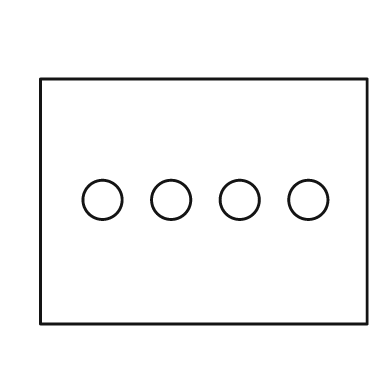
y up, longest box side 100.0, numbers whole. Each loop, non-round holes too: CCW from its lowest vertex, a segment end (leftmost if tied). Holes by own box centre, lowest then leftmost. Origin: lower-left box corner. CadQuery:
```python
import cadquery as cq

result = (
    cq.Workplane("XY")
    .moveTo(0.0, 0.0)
    .lineTo(100.0, 0.0)
    .lineTo(100.0, 75.0)
    .lineTo(0.0, 75.0)
    .close()
    .moveTo(19.0, 38.0)
    .circle(6.0)
    .moveTo(40.0, 38.0)
    .circle(6.0)
    .moveTo(61.0, 38.0)
    .circle(6.0)
    .moveTo(82.0, 38.0)
    .circle(6.0)
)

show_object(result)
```